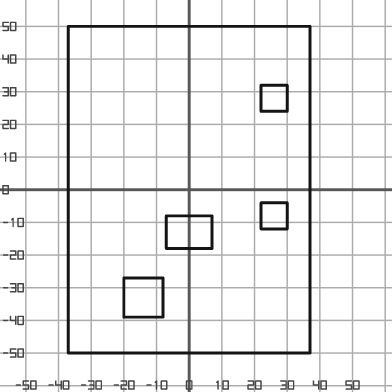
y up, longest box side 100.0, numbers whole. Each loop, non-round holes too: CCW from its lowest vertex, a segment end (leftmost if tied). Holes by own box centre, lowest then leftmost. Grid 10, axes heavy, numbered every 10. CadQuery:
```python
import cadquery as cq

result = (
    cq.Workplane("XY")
    .moveTo(-37.0, -50.0)
    .lineTo(37.0, -50.0)
    .lineTo(37.0, 50.0)
    .lineTo(-37.0, 50.0)
    .close()
    .moveTo(-20.0, -39.0)
    .lineTo(-8.0, -39.0)
    .lineTo(-8.0, -27.0)
    .lineTo(-20.0, -27.0)
    .close()
    .moveTo(-7.0, -18.0)
    .lineTo(7.0, -18.0)
    .lineTo(7.0, -8.0)
    .lineTo(-7.0, -8.0)
    .close()
    .moveTo(22.0, -12.0)
    .lineTo(30.0, -12.0)
    .lineTo(30.0, -4.0)
    .lineTo(22.0, -4.0)
    .close()
    .moveTo(22.0, 24.0)
    .lineTo(30.0, 24.0)
    .lineTo(30.0, 32.0)
    .lineTo(22.0, 32.0)
    .close()
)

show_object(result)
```